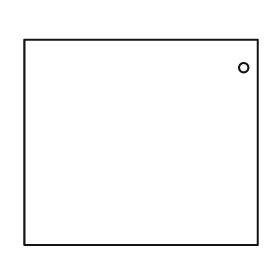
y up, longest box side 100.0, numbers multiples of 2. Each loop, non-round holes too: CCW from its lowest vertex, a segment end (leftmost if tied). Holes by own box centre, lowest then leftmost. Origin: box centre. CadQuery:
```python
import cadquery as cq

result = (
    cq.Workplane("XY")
    .moveTo(-50.0, -44.0)
    .lineTo(50.0, -44.0)
    .lineTo(50.0, 44.0)
    .lineTo(-50.0, 44.0)
    .close()
    .moveTo(44.0, 32.0)
    .circle(2.0)
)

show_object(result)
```